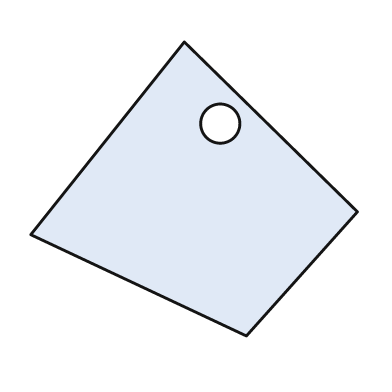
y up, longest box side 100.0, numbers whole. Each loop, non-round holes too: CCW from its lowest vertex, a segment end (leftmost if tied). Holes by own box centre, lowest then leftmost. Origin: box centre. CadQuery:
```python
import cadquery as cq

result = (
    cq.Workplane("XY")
    .moveTo(16.0, -45.0)
    .lineTo(50.0, -7.0)
    .lineTo(-3.0, 45.0)
    .lineTo(-50.0, -14.0)
    .close()
    .moveTo(8.0, 20.0)
    .circle(6.0)
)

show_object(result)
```